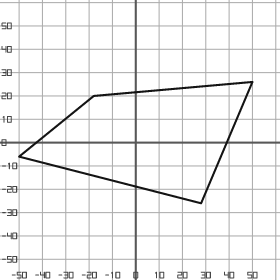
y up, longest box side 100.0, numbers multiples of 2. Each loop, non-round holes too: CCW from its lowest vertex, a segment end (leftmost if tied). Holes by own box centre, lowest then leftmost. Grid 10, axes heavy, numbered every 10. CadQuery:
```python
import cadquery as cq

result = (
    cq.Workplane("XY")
    .moveTo(28.0, -26.0)
    .lineTo(50.0, 26.0)
    .lineTo(-18.0, 20.0)
    .lineTo(-50.0, -6.0)
    .close()
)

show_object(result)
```